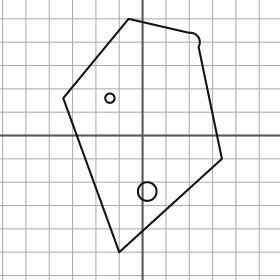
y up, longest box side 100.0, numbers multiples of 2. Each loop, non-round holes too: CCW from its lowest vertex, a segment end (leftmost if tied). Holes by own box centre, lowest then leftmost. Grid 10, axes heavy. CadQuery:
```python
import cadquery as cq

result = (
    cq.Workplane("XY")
    .moveTo(-10.0, -50.0)
    .lineTo(34.0, -10.0)
    .lineTo(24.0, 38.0)
    .threePointArc((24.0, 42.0), (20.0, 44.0))
    .lineTo(-6.0, 50.0)
    .lineTo(-34.0, 16.0)
    .close()
    .moveTo(2.0, -24.0)
    .circle(4.0)
    .moveTo(-14.0, 16.0)
    .circle(2.0)
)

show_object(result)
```